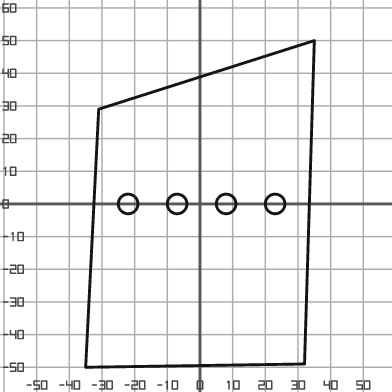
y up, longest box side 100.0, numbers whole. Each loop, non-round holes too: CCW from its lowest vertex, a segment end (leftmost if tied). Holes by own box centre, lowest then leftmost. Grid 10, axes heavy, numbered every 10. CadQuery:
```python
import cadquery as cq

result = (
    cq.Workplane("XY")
    .moveTo(-35.0, -50.0)
    .lineTo(32.0, -49.0)
    .lineTo(35.0, 50.0)
    .lineTo(-31.0, 29.0)
    .close()
    .moveTo(-22.0, 0.0)
    .circle(3.0)
    .moveTo(-7.0, 0.0)
    .circle(3.0)
    .moveTo(8.0, 0.0)
    .circle(3.0)
    .moveTo(23.0, 0.0)
    .circle(3.0)
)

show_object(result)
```